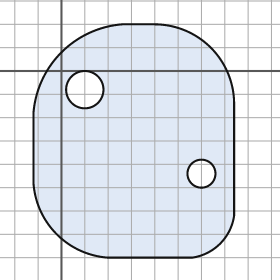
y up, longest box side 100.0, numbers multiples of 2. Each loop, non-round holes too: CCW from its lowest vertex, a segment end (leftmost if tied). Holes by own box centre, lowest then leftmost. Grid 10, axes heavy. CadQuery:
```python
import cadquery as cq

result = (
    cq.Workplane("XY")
    .moveTo(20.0, -80.0)
    .lineTo(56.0, -80.0)
    .threePointArc((68.0, -74.0), (74.0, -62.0))
    .lineTo(74.0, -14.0)
    .threePointArc((64.0, 10.0), (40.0, 20.0))
    .lineTo(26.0, 20.0)
    .threePointArc((0.0, 8.0), (-12.0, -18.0))
    .lineTo(-12.0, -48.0)
    .threePointArc((-2.0, -70.0), (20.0, -80.0))
    .close()
    .moveTo(60.0, -44.0)
    .circle(6.0)
    .moveTo(10.0, -8.0)
    .circle(8.0)
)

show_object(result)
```